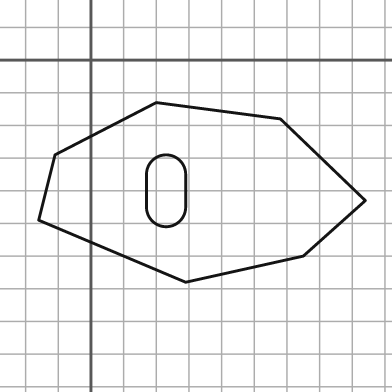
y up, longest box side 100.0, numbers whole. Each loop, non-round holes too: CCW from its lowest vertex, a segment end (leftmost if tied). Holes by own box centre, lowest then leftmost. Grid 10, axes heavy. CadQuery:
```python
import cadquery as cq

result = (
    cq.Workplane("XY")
    .moveTo(29.0, -68.0)
    .lineTo(65.0, -60.0)
    .lineTo(84.0, -43.0)
    .lineTo(58.0, -18.0)
    .lineTo(20.0, -13.0)
    .lineTo(-11.0, -29.0)
    .lineTo(-16.0, -49.0)
    .close()
    .moveTo(17.0, -45.0)
    .threePointArc((23.0, -51.0), (29.0, -45.0))
    .lineTo(29.0, -35.0)
    .threePointArc((23.0, -29.0), (17.0, -35.0))
    .close()
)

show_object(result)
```